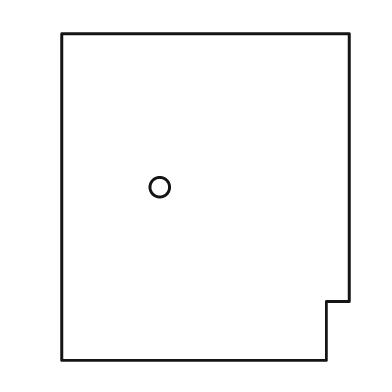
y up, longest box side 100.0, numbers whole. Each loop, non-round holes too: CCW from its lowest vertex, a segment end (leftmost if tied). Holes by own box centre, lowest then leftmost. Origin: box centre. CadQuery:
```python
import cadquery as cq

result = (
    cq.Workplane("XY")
    .moveTo(-44.0, -50.0)
    .lineTo(37.0, -50.0)
    .lineTo(37.0, -32.0)
    .lineTo(44.0, -32.0)
    .lineTo(44.0, 50.0)
    .lineTo(-44.0, 50.0)
    .close()
    .moveTo(-14.0, 3.0)
    .circle(3.0)
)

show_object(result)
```